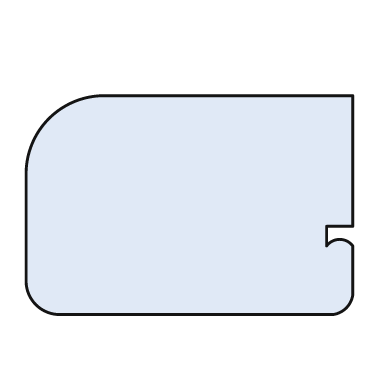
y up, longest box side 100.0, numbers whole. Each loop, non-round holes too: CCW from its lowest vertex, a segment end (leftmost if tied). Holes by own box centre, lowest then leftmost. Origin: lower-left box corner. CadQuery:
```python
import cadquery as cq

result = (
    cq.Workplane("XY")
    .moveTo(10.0, 0.0)
    .lineTo(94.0, 0.0)
    .threePointArc((98.0, 2.0), (100.0, 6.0))
    .lineTo(100.0, 21.0)
    .threePointArc((96.0, 23.0), (92.0, 21.0))
    .lineTo(92.0, 27.0)
    .lineTo(100.0, 27.0)
    .lineTo(100.0, 67.0)
    .lineTo(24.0, 67.0)
    .threePointArc((7.0, 60.0), (0.0, 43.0))
    .lineTo(0.0, 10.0)
    .threePointArc((3.0, 3.0), (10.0, 0.0))
    .close()
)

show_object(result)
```